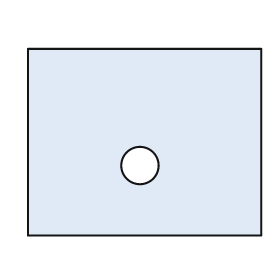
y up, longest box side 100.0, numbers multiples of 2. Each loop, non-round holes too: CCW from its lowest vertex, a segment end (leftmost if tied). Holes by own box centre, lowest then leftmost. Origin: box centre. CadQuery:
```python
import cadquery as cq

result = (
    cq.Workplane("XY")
    .moveTo(-50.0, -40.0)
    .lineTo(50.0, -40.0)
    .lineTo(50.0, 40.0)
    .lineTo(-50.0, 40.0)
    .close()
    .moveTo(-2.0, -10.0)
    .circle(8.0)
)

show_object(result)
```